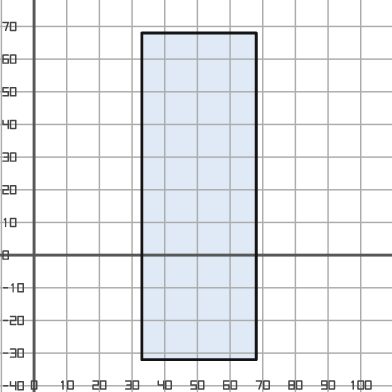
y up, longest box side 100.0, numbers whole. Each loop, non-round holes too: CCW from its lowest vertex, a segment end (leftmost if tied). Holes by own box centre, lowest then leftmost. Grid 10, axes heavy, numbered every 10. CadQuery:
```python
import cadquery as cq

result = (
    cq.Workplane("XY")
    .moveTo(33.0, -32.0)
    .lineTo(68.0, -32.0)
    .lineTo(68.0, 68.0)
    .lineTo(33.0, 68.0)
    .close()
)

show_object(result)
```